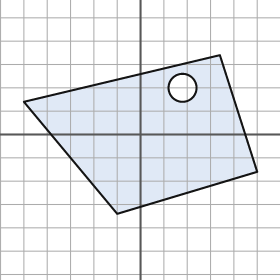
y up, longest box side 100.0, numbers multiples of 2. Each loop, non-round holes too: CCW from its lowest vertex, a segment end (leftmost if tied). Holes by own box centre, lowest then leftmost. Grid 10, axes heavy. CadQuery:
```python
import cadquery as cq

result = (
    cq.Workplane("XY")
    .moveTo(-10.0, -34.0)
    .lineTo(50.0, -16.0)
    .lineTo(34.0, 34.0)
    .lineTo(-50.0, 14.0)
    .close()
    .moveTo(18.0, 20.0)
    .circle(6.0)
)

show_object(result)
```